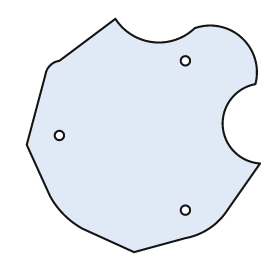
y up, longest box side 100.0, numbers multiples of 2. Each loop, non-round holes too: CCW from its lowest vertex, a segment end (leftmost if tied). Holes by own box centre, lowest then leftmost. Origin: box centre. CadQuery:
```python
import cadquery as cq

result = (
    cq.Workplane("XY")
    .moveTo(-4.0, -50.0)
    .lineTo(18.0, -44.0)
    .threePointArc((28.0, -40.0), (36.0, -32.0))
    .lineTo(50.0, -12.0)
    .threePointArc((34.0, 4.0), (48.0, 22.0))
    .threePointArc((42.0, 42.0), (22.0, 46.0))
    .threePointArc((4.0, 40.0), (-12.0, 50.0))
    .lineTo(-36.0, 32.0)
    .threePointArc((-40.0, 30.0), (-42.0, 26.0))
    .lineTo(-50.0, -4.0)
    .lineTo(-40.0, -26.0)
    .threePointArc((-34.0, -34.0), (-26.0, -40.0))
    .close()
    .moveTo(18.0, -32.0)
    .circle(2.0)
    .moveTo(-36.0, 0.0)
    .circle(2.0)
    .moveTo(18.0, 32.0)
    .circle(2.0)
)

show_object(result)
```